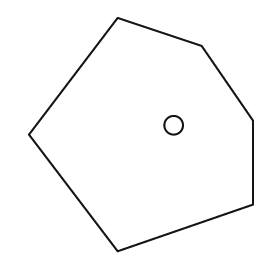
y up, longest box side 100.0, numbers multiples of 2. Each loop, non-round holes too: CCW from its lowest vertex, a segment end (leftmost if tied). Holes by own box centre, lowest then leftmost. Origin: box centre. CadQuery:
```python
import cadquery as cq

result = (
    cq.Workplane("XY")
    .moveTo(-10.0, -50.0)
    .lineTo(48.0, -30.0)
    .lineTo(48.0, 6.0)
    .lineTo(26.0, 38.0)
    .lineTo(-10.0, 50.0)
    .lineTo(-48.0, 0.0)
    .close()
    .moveTo(14.0, 4.0)
    .circle(4.0)
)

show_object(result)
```